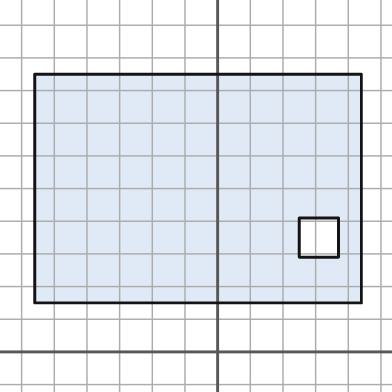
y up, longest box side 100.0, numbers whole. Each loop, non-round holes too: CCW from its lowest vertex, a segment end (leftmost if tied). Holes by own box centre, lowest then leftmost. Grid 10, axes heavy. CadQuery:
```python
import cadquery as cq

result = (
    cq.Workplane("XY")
    .moveTo(-56.0, 15.0)
    .lineTo(44.0, 15.0)
    .lineTo(44.0, 85.0)
    .lineTo(-56.0, 85.0)
    .close()
    .moveTo(25.0, 29.0)
    .lineTo(37.0, 29.0)
    .lineTo(37.0, 41.0)
    .lineTo(25.0, 41.0)
    .close()
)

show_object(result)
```